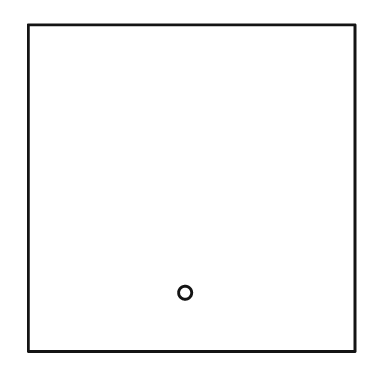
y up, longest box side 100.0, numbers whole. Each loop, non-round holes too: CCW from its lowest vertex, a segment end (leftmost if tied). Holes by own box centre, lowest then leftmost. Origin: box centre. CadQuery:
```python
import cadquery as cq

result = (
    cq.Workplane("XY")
    .moveTo(-50.0, -50.0)
    .lineTo(50.0, -50.0)
    .lineTo(50.0, 50.0)
    .lineTo(-50.0, 50.0)
    .close()
    .moveTo(-2.0, -32.0)
    .circle(2.0)
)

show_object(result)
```